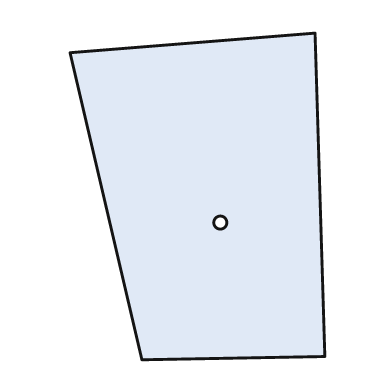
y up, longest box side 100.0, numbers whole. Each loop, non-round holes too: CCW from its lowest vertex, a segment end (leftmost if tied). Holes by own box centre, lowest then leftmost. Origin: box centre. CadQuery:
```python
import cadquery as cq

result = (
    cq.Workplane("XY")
    .moveTo(-17.0, -50.0)
    .lineTo(39.0, -49.0)
    .lineTo(36.0, 50.0)
    .lineTo(-39.0, 44.0)
    .close()
    .moveTo(7.0, -8.0)
    .circle(2.0)
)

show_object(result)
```